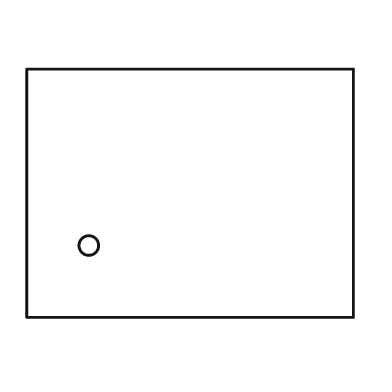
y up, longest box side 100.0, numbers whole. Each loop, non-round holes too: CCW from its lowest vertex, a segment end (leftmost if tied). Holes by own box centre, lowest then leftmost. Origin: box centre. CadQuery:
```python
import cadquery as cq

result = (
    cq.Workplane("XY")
    .moveTo(-50.0, -38.0)
    .lineTo(50.0, -38.0)
    .lineTo(50.0, 38.0)
    .lineTo(-50.0, 38.0)
    .close()
    .moveTo(-31.0, -16.0)
    .circle(3.0)
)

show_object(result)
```